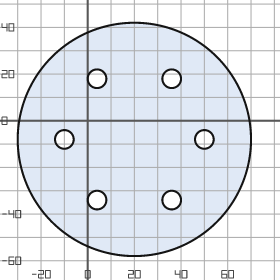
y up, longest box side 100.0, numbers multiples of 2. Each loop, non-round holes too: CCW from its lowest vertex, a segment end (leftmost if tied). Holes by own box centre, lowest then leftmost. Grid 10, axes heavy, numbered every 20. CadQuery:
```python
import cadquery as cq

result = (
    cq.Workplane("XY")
    .moveTo(20.0, -8.0)
    .circle(50.0)
    .moveTo(4.0, -34.0)
    .circle(4.0)
    .moveTo(36.0, -34.0)
    .circle(4.0)
    .moveTo(-10.0, -8.0)
    .circle(4.0)
    .moveTo(50.0, -8.0)
    .circle(4.0)
    .moveTo(4.0, 18.0)
    .circle(4.0)
    .moveTo(36.0, 18.0)
    .circle(4.0)
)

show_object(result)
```